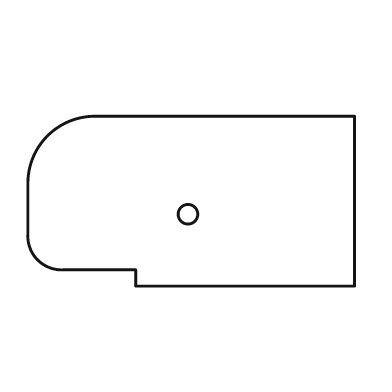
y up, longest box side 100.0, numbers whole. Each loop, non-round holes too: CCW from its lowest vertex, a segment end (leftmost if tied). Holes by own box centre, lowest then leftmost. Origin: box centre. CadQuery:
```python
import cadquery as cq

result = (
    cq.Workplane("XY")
    .moveTo(-17.0, -26.0)
    .lineTo(50.0, -26.0)
    .lineTo(50.0, 26.0)
    .lineTo(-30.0, 26.0)
    .threePointArc((-44.0, 20.0), (-50.0, 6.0))
    .lineTo(-50.0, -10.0)
    .threePointArc((-47.0, -18.0), (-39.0, -21.0))
    .lineTo(-17.0, -21.0)
    .close()
    .moveTo(-1.0, -4.0)
    .circle(3.0)
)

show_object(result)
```